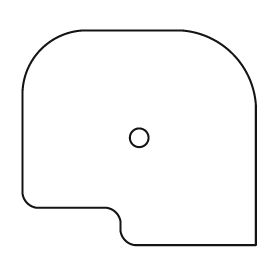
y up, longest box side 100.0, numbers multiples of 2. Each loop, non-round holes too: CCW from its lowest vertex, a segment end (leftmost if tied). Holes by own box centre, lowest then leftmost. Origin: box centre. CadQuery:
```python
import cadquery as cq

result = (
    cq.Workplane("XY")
    .moveTo(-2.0, -46.0)
    .lineTo(50.0, -46.0)
    .lineTo(50.0, 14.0)
    .threePointArc((40.0, 36.0), (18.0, 46.0))
    .lineTo(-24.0, 46.0)
    .threePointArc((-42.0, 38.0), (-50.0, 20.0))
    .lineTo(-50.0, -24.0)
    .threePointArc((-48.0, -28.0), (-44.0, -30.0))
    .lineTo(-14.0, -30.0)
    .threePointArc((-10.0, -32.0), (-8.0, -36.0))
    .lineTo(-8.0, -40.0)
    .threePointArc((-6.0, -44.0), (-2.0, -46.0))
    .close()
    .moveTo(0.0, 0.0)
    .circle(4.0)
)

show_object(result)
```